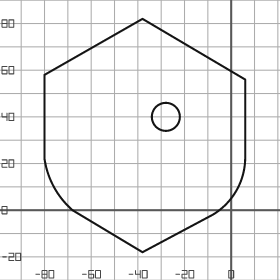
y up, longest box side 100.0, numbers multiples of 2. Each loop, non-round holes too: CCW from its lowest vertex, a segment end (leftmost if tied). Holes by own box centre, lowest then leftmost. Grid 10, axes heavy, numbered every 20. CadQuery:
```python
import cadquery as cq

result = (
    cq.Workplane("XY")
    .moveTo(-38.0, -18.0)
    .lineTo(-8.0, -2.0)
    .threePointArc((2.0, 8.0), (6.0, 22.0))
    .lineTo(6.0, 56.0)
    .lineTo(-38.0, 82.0)
    .lineTo(-80.0, 58.0)
    .lineTo(-80.0, 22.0)
    .threePointArc((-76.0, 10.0), (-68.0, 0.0))
    .close()
    .moveTo(-28.0, 40.0)
    .circle(6.0)
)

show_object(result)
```